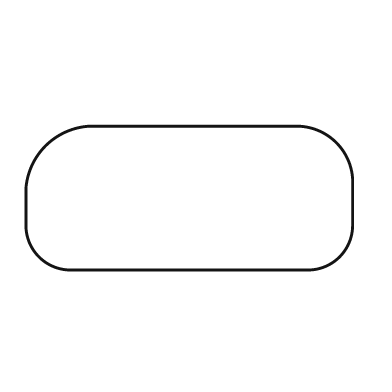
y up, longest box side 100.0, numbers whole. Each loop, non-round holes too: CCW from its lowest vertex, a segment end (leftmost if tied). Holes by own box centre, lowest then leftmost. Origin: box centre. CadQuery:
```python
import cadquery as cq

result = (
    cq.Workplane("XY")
    .moveTo(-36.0, -22.0)
    .lineTo(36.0, -22.0)
    .threePointArc((46.0, -18.0), (50.0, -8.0))
    .lineTo(50.0, 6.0)
    .threePointArc((45.0, 17.0), (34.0, 22.0))
    .lineTo(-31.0, 22.0)
    .threePointArc((-44.0, 16.0), (-50.0, 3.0))
    .lineTo(-50.0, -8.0)
    .threePointArc((-46.0, -18.0), (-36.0, -22.0))
    .close()
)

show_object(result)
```